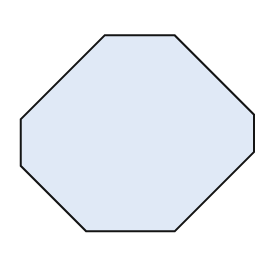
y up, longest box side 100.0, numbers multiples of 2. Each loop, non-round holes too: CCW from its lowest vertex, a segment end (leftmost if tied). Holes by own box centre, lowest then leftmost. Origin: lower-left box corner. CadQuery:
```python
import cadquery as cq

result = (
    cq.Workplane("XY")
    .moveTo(28.0, 0.0)
    .lineTo(66.0, 0.0)
    .lineTo(100.0, 34.0)
    .lineTo(100.0, 50.0)
    .lineTo(66.0, 84.0)
    .lineTo(36.0, 84.0)
    .lineTo(0.0, 48.0)
    .lineTo(0.0, 28.0)
    .close()
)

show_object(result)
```